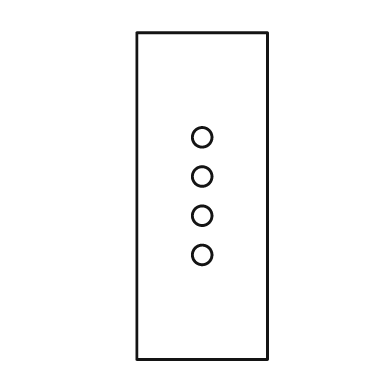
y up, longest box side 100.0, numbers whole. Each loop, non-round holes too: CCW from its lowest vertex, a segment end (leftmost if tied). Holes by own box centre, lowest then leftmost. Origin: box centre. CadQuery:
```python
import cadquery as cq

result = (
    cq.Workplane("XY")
    .moveTo(-20.0, -50.0)
    .lineTo(20.0, -50.0)
    .lineTo(20.0, 50.0)
    .lineTo(-20.0, 50.0)
    .close()
    .moveTo(0.0, -18.0)
    .circle(3.0)
    .moveTo(0.0, -6.0)
    .circle(3.0)
    .moveTo(0.0, 6.0)
    .circle(3.0)
    .moveTo(0.0, 18.0)
    .circle(3.0)
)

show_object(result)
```